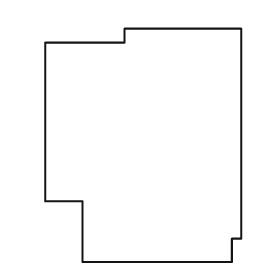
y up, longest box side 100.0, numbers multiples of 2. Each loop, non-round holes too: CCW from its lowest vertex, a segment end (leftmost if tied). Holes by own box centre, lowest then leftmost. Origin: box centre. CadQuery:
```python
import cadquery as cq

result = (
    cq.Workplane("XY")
    .moveTo(-26.0, -50.0)
    .lineTo(38.0, -50.0)
    .lineTo(38.0, -40.0)
    .lineTo(42.0, -40.0)
    .lineTo(42.0, 50.0)
    .lineTo(-8.0, 50.0)
    .lineTo(-8.0, 44.0)
    .lineTo(-42.0, 44.0)
    .lineTo(-42.0, -24.0)
    .lineTo(-26.0, -24.0)
    .close()
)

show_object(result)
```